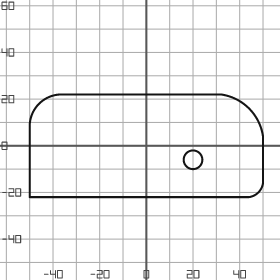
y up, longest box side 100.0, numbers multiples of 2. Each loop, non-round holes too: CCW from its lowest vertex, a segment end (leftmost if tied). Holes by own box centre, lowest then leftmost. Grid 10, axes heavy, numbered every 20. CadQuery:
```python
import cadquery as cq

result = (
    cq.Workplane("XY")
    .moveTo(-50.0, -22.0)
    .lineTo(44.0, -22.0)
    .threePointArc((48.0, -20.0), (50.0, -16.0))
    .lineTo(50.0, 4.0)
    .threePointArc((44.0, 16.0), (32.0, 22.0))
    .lineTo(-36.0, 22.0)
    .threePointArc((-46.0, 18.0), (-50.0, 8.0))
    .close()
    .moveTo(20.0, -6.0)
    .circle(4.0)
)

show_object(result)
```